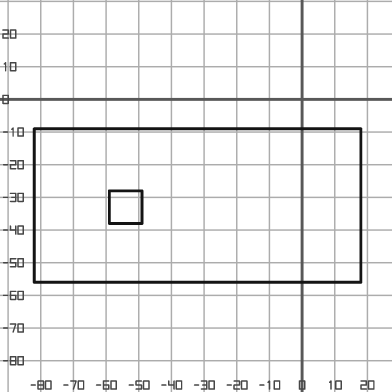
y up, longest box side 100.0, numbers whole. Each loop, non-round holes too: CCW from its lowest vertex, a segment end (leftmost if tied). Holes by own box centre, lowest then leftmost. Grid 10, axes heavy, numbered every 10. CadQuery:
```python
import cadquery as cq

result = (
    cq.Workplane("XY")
    .moveTo(-82.0, -56.0)
    .lineTo(18.0, -56.0)
    .lineTo(18.0, -9.0)
    .lineTo(-82.0, -9.0)
    .close()
    .moveTo(-59.0, -38.0)
    .lineTo(-49.0, -38.0)
    .lineTo(-49.0, -28.0)
    .lineTo(-59.0, -28.0)
    .close()
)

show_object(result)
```